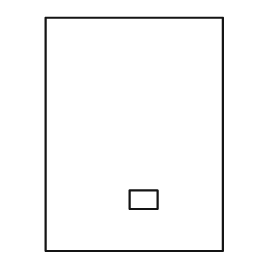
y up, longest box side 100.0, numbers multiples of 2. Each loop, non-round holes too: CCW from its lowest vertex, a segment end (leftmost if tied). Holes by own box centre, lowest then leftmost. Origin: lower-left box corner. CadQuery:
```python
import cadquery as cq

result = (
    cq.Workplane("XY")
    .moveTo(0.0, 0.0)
    .lineTo(76.0, 0.0)
    .lineTo(76.0, 100.0)
    .lineTo(0.0, 100.0)
    .close()
    .moveTo(36.0, 18.0)
    .lineTo(48.0, 18.0)
    .lineTo(48.0, 26.0)
    .lineTo(36.0, 26.0)
    .close()
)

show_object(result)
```